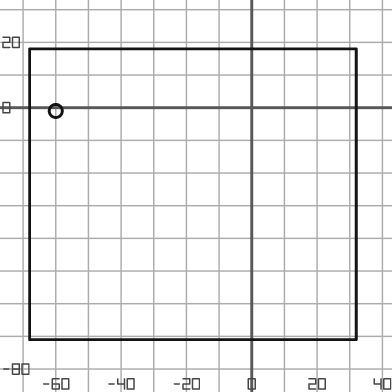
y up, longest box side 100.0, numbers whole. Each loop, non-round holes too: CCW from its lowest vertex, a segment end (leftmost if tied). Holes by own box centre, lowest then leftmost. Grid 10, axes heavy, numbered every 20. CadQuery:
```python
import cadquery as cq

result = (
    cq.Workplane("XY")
    .moveTo(-68.0, -71.0)
    .lineTo(32.0, -71.0)
    .lineTo(32.0, 18.0)
    .lineTo(-68.0, 18.0)
    .close()
    .moveTo(-60.0, -1.0)
    .circle(2.0)
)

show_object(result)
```